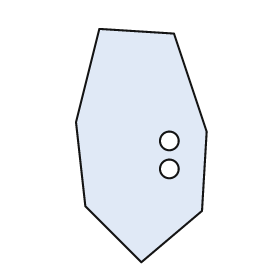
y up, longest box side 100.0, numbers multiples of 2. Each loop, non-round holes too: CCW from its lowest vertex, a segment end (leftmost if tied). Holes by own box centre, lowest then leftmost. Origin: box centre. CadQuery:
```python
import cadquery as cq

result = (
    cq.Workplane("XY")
    .moveTo(0.0, -50.0)
    .lineTo(26.0, -28.0)
    .lineTo(28.0, 6.0)
    .lineTo(14.0, 48.0)
    .lineTo(-18.0, 50.0)
    .lineTo(-28.0, 10.0)
    .lineTo(-24.0, -26.0)
    .close()
    .moveTo(12.0, -10.0)
    .circle(4.0)
    .moveTo(12.0, 2.0)
    .circle(4.0)
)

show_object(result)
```